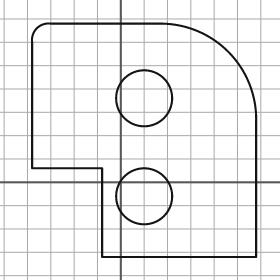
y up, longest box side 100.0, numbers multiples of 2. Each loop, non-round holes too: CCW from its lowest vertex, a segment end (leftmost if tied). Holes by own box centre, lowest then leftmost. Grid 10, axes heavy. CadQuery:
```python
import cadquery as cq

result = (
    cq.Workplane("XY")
    .moveTo(-8.0, -32.0)
    .lineTo(58.0, -32.0)
    .lineTo(58.0, 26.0)
    .threePointArc((46.0, 56.0), (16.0, 68.0))
    .lineTo(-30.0, 68.0)
    .threePointArc((-36.0, 66.0), (-38.0, 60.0))
    .lineTo(-38.0, 6.0)
    .lineTo(-8.0, 6.0)
    .close()
    .moveTo(10.0, -6.0)
    .circle(12.0)
    .moveTo(10.0, 36.0)
    .circle(12.0)
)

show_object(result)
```